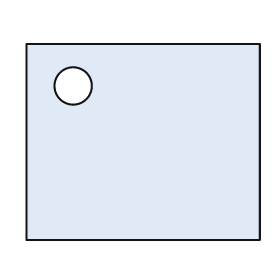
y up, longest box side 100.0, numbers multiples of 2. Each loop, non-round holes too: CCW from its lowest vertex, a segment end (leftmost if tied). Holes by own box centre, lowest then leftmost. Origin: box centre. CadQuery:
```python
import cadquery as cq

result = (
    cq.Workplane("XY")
    .moveTo(-50.0, -42.0)
    .lineTo(50.0, -42.0)
    .lineTo(50.0, 42.0)
    .lineTo(-50.0, 42.0)
    .close()
    .moveTo(-30.0, 24.0)
    .circle(8.0)
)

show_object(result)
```